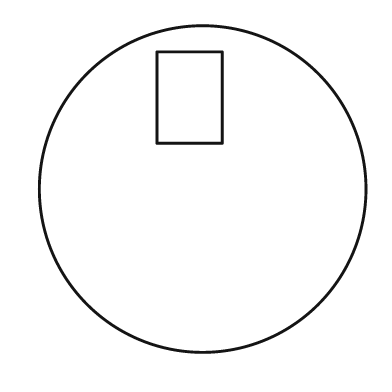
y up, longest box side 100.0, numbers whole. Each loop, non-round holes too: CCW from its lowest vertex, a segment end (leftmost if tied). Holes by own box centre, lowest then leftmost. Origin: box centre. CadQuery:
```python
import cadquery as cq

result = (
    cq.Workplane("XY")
    .moveTo(0.0, 0.0)
    .circle(50.0)
    .moveTo(-14.0, 14.0)
    .lineTo(6.0, 14.0)
    .lineTo(6.0, 42.0)
    .lineTo(-14.0, 42.0)
    .close()
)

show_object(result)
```